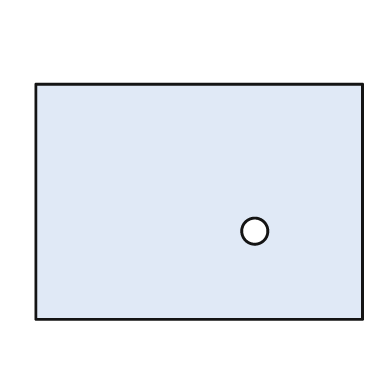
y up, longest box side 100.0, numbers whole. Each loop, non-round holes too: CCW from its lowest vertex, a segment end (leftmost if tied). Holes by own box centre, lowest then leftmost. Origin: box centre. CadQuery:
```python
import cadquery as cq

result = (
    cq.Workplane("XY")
    .moveTo(-50.0, -36.0)
    .lineTo(50.0, -36.0)
    .lineTo(50.0, 36.0)
    .lineTo(-50.0, 36.0)
    .close()
    .moveTo(17.0, -9.0)
    .circle(4.0)
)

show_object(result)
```